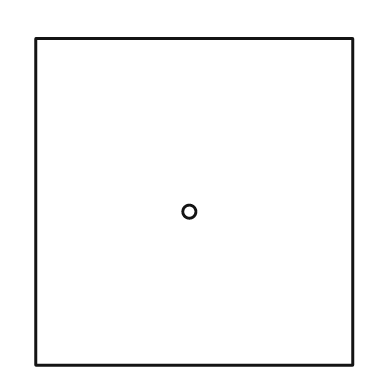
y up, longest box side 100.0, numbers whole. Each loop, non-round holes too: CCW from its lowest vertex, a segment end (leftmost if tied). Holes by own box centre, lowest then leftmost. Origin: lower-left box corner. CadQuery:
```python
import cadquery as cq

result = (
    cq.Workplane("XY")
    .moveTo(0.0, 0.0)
    .lineTo(97.0, 0.0)
    .lineTo(97.0, 100.0)
    .lineTo(0.0, 100.0)
    .close()
    .moveTo(47.0, 47.0)
    .circle(2.0)
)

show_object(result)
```